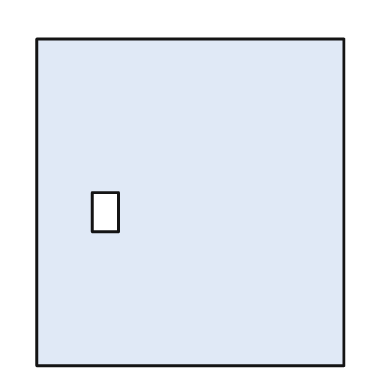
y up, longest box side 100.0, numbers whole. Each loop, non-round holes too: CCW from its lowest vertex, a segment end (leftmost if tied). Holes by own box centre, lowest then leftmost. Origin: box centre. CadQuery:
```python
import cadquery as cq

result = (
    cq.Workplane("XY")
    .moveTo(-47.0, -50.0)
    .lineTo(47.0, -50.0)
    .lineTo(47.0, 50.0)
    .lineTo(-47.0, 50.0)
    .close()
    .moveTo(-30.0, -9.0)
    .lineTo(-22.0, -9.0)
    .lineTo(-22.0, 3.0)
    .lineTo(-30.0, 3.0)
    .close()
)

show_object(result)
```